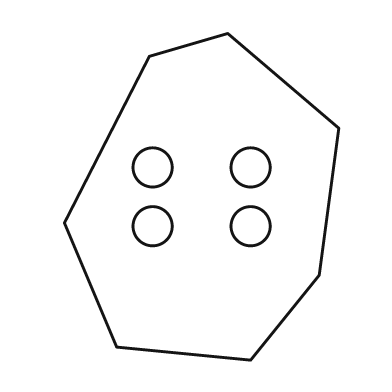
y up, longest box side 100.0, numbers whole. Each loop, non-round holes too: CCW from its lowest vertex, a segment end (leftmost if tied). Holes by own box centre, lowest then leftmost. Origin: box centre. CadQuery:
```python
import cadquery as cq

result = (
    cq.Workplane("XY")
    .moveTo(15.0, -50.0)
    .lineTo(36.0, -24.0)
    .lineTo(42.0, 21.0)
    .lineTo(8.0, 50.0)
    .lineTo(-16.0, 43.0)
    .lineTo(-42.0, -8.0)
    .lineTo(-26.0, -46.0)
    .close()
    .moveTo(-15.0, -9.0)
    .circle(6.0)
    .moveTo(15.0, -9.0)
    .circle(6.0)
    .moveTo(-15.0, 9.0)
    .circle(6.0)
    .moveTo(15.0, 9.0)
    .circle(6.0)
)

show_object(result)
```